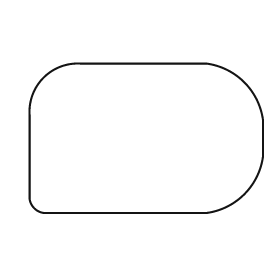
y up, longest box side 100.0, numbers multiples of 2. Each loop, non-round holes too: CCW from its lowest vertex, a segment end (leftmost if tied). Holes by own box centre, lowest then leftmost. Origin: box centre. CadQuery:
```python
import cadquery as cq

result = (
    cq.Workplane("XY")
    .moveTo(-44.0, -32.0)
    .lineTo(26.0, -32.0)
    .threePointArc((42.0, -24.0), (50.0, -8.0))
    .lineTo(50.0, 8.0)
    .threePointArc((42.0, 24.0), (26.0, 32.0))
    .lineTo(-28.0, 32.0)
    .threePointArc((-44.0, 26.0), (-50.0, 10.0))
    .lineTo(-50.0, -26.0)
    .threePointArc((-48.0, -30.0), (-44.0, -32.0))
    .close()
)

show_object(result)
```